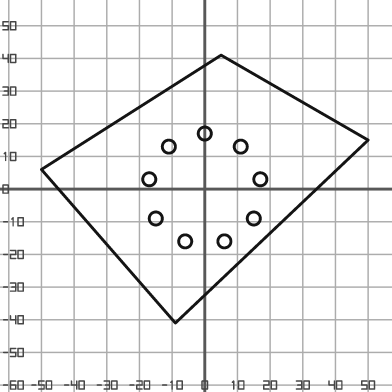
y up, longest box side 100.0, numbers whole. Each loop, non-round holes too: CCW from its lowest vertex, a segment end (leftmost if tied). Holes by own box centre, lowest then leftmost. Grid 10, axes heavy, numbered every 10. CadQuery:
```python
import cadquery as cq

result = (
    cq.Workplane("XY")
    .moveTo(-9.0, -41.0)
    .lineTo(50.0, 15.0)
    .lineTo(5.0, 41.0)
    .lineTo(-50.0, 6.0)
    .close()
    .moveTo(-6.0, -16.0)
    .circle(2.0)
    .moveTo(6.0, -16.0)
    .circle(2.0)
    .moveTo(-15.0, -9.0)
    .circle(2.0)
    .moveTo(15.0, -9.0)
    .circle(2.0)
    .moveTo(-17.0, 3.0)
    .circle(2.0)
    .moveTo(17.0, 3.0)
    .circle(2.0)
    .moveTo(-11.0, 13.0)
    .circle(2.0)
    .moveTo(11.0, 13.0)
    .circle(2.0)
    .moveTo(0.0, 17.0)
    .circle(2.0)
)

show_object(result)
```